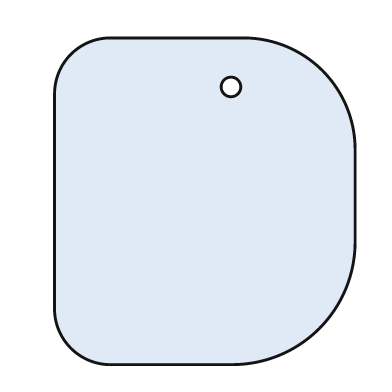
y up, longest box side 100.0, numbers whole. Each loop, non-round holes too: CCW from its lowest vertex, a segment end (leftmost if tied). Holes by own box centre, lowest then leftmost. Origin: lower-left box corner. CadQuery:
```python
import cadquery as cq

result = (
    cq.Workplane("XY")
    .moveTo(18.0, 0.0)
    .lineTo(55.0, 0.0)
    .threePointArc((81.0, 11.0), (92.0, 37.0))
    .lineTo(92.0, 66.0)
    .threePointArc((82.0, 90.0), (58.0, 100.0))
    .lineTo(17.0, 100.0)
    .threePointArc((5.0, 95.0), (0.0, 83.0))
    .lineTo(0.0, 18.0)
    .threePointArc((5.0, 5.0), (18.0, 0.0))
    .close()
    .moveTo(54.0, 85.0)
    .circle(3.0)
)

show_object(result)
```